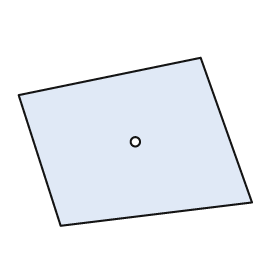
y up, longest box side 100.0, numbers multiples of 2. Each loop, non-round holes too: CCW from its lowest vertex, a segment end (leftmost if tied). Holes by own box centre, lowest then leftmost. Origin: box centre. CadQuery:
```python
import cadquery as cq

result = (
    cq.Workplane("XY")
    .moveTo(-32.0, -36.0)
    .lineTo(50.0, -26.0)
    .lineTo(28.0, 36.0)
    .lineTo(-50.0, 20.0)
    .close()
    .moveTo(0.0, 0.0)
    .circle(2.0)
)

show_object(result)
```